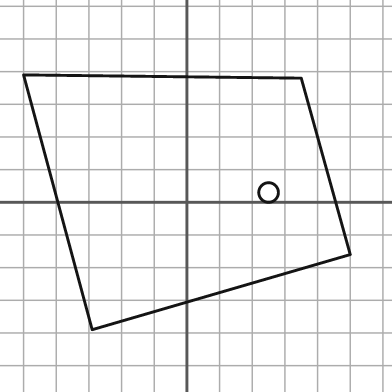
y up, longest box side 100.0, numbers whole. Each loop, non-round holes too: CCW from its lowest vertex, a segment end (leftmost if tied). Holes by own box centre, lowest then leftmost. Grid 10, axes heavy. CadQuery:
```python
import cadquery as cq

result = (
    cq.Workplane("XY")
    .moveTo(-29.0, -39.0)
    .lineTo(50.0, -16.0)
    .lineTo(35.0, 38.0)
    .lineTo(-50.0, 39.0)
    .close()
    .moveTo(25.0, 3.0)
    .circle(3.0)
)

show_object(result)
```